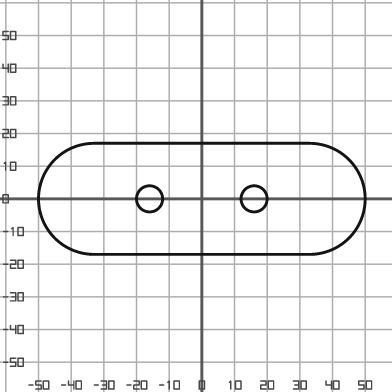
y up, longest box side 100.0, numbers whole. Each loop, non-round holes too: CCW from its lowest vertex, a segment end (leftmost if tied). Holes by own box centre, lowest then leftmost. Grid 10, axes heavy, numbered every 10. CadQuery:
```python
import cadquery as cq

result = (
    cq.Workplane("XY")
    .moveTo(-33.0, -17.0)
    .lineTo(33.0, -17.0)
    .threePointArc((50.0, 0.0), (33.0, 17.0))
    .lineTo(-33.0, 17.0)
    .threePointArc((-50.0, 0.0), (-33.0, -17.0))
    .close()
    .moveTo(-16.0, 0.0)
    .circle(4.0)
    .moveTo(16.0, 0.0)
    .circle(4.0)
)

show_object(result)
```